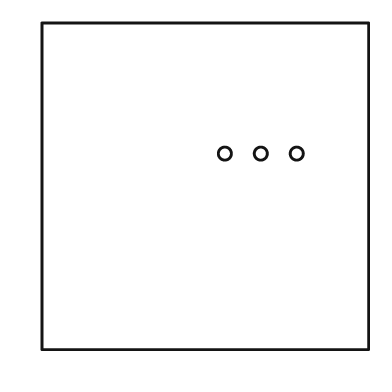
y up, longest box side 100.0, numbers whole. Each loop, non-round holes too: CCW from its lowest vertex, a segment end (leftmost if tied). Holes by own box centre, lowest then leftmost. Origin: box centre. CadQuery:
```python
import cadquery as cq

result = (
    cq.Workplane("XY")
    .moveTo(-50.0, -50.0)
    .lineTo(50.0, -50.0)
    .lineTo(50.0, 50.0)
    .lineTo(-50.0, 50.0)
    .close()
    .moveTo(6.0, 10.0)
    .circle(2.0)
    .moveTo(17.0, 10.0)
    .circle(2.0)
    .moveTo(28.0, 10.0)
    .circle(2.0)
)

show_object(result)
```